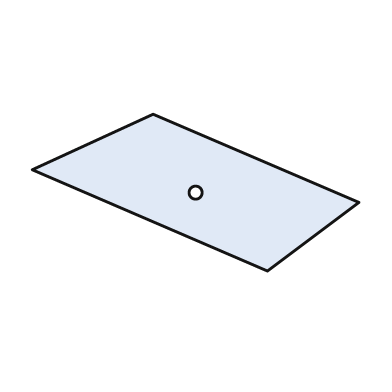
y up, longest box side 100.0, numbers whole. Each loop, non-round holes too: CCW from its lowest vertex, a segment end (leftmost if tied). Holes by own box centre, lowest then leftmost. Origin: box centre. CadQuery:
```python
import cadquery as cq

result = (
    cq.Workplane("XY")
    .moveTo(22.0, -24.0)
    .lineTo(50.0, -3.0)
    .lineTo(-13.0, 24.0)
    .lineTo(-50.0, 7.0)
    .close()
    .moveTo(0.0, 0.0)
    .circle(2.0)
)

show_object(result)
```